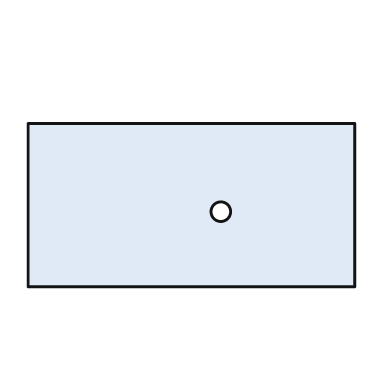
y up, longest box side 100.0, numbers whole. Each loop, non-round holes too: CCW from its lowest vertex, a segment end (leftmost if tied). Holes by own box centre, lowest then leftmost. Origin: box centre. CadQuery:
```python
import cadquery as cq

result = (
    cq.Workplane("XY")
    .moveTo(-50.0, -25.0)
    .lineTo(50.0, -25.0)
    .lineTo(50.0, 25.0)
    .lineTo(-50.0, 25.0)
    .close()
    .moveTo(9.0, -2.0)
    .circle(3.0)
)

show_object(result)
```